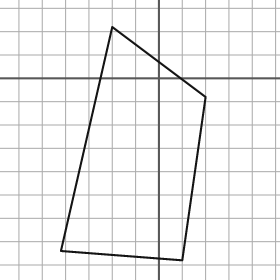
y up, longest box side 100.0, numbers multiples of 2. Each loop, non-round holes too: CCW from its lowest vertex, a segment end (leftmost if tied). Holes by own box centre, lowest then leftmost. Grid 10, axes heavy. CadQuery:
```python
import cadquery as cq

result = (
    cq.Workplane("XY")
    .moveTo(10.0, -78.0)
    .lineTo(20.0, -8.0)
    .lineTo(-20.0, 22.0)
    .lineTo(-42.0, -74.0)
    .close()
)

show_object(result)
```